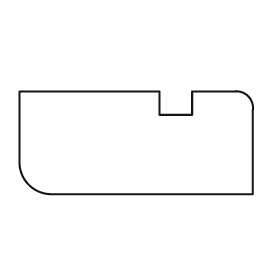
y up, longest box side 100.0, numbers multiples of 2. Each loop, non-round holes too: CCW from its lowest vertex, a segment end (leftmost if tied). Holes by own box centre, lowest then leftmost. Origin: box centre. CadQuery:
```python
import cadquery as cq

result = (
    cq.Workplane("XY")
    .moveTo(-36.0, -22.0)
    .lineTo(50.0, -22.0)
    .lineTo(50.0, 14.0)
    .threePointArc((48.0, 20.0), (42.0, 22.0))
    .lineTo(24.0, 22.0)
    .lineTo(24.0, 12.0)
    .lineTo(10.0, 12.0)
    .lineTo(10.0, 22.0)
    .lineTo(-50.0, 22.0)
    .lineTo(-50.0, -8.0)
    .threePointArc((-46.0, -18.0), (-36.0, -22.0))
    .close()
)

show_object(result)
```